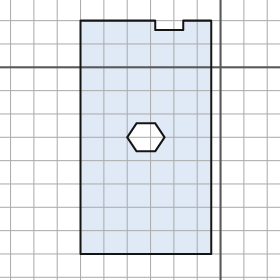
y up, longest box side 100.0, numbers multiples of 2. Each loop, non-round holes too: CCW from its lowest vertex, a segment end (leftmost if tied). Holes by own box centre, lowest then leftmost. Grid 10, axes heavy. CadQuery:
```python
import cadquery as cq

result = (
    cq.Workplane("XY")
    .moveTo(-60.0, -80.0)
    .lineTo(-4.0, -80.0)
    .lineTo(-4.0, 20.0)
    .lineTo(-16.0, 20.0)
    .lineTo(-16.0, 16.0)
    .lineTo(-28.0, 16.0)
    .lineTo(-28.0, 20.0)
    .lineTo(-60.0, 20.0)
    .close()
    .moveTo(-36.0, -36.0)
    .lineTo(-28.0, -36.0)
    .lineTo(-24.0, -30.0)
    .lineTo(-28.0, -24.0)
    .lineTo(-36.0, -24.0)
    .lineTo(-40.0, -30.0)
    .close()
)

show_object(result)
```